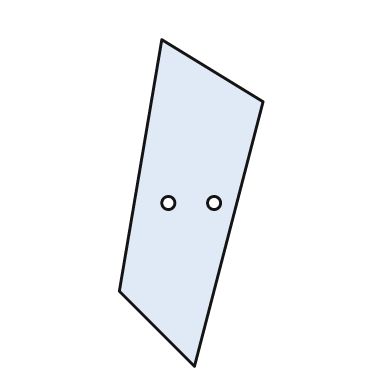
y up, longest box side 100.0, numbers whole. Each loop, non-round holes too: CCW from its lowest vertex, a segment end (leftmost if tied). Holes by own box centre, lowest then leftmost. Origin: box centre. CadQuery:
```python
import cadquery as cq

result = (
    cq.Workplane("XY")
    .moveTo(1.0, -50.0)
    .lineTo(22.0, 31.0)
    .lineTo(-9.0, 50.0)
    .lineTo(-22.0, -27.0)
    .close()
    .moveTo(-7.0, 0.0)
    .circle(2.0)
    .moveTo(7.0, 0.0)
    .circle(2.0)
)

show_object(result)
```